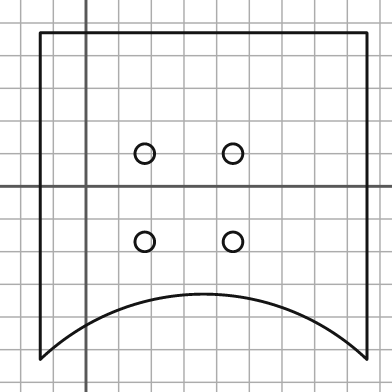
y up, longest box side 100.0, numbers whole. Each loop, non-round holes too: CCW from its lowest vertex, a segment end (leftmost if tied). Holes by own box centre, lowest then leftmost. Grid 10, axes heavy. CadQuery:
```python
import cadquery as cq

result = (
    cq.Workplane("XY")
    .moveTo(-14.0, -53.0)
    .threePointArc((36.0, -33.0), (86.0, -53.0))
    .lineTo(86.0, 47.0)
    .lineTo(-14.0, 47.0)
    .close()
    .moveTo(18.0, -17.0)
    .circle(3.0)
    .moveTo(45.0, -17.0)
    .circle(3.0)
    .moveTo(18.0, 10.0)
    .circle(3.0)
    .moveTo(45.0, 10.0)
    .circle(3.0)
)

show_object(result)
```